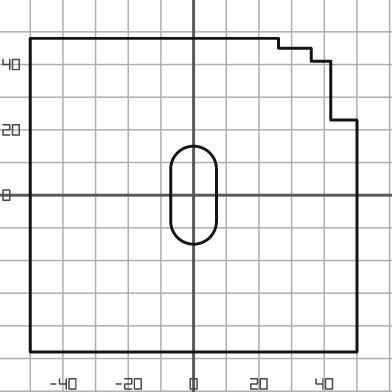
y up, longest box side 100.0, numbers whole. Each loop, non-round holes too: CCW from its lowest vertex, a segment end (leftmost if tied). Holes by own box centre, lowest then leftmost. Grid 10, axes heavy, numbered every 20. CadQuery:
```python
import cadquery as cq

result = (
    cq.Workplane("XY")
    .moveTo(-50.0, -48.0)
    .lineTo(50.0, -48.0)
    .lineTo(50.0, 23.0)
    .lineTo(42.0, 23.0)
    .lineTo(42.0, 41.0)
    .lineTo(36.0, 41.0)
    .lineTo(36.0, 45.0)
    .lineTo(26.0, 45.0)
    .lineTo(26.0, 48.0)
    .lineTo(-50.0, 48.0)
    .close()
    .moveTo(-7.0, -8.0)
    .threePointArc((0.0, -15.0), (7.0, -8.0))
    .lineTo(7.0, 8.0)
    .threePointArc((0.0, 15.0), (-7.0, 8.0))
    .close()
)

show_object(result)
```